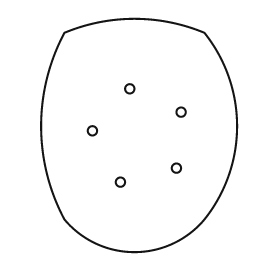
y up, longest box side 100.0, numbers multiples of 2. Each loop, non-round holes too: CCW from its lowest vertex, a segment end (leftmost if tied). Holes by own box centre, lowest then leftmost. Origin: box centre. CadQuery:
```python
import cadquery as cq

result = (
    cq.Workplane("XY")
    .moveTo(-32.0, -36.0)
    .threePointArc((-2.0, -50.0), (28.0, -36.0))
    .threePointArc((42.0, 4.0), (28.0, 44.0))
    .threePointArc((-2.0, 50.0), (-32.0, 44.0))
    .threePointArc((-42.0, 4.0), (-32.0, -36.0))
    .close()
    .moveTo(-8.0, -20.0)
    .circle(2.0)
    .moveTo(16.0, -14.0)
    .circle(2.0)
    .moveTo(-20.0, 2.0)
    .circle(2.0)
    .moveTo(18.0, 10.0)
    .circle(2.0)
    .moveTo(-4.0, 20.0)
    .circle(2.0)
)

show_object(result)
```